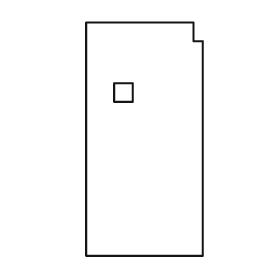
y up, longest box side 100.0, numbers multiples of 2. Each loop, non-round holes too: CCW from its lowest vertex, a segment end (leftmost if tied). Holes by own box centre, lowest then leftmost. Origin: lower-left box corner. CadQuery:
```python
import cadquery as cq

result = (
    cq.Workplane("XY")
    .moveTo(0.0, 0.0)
    .lineTo(50.0, 0.0)
    .lineTo(50.0, 92.0)
    .lineTo(46.0, 92.0)
    .lineTo(46.0, 100.0)
    .lineTo(0.0, 100.0)
    .close()
    .moveTo(12.0, 66.0)
    .lineTo(20.0, 66.0)
    .lineTo(20.0, 74.0)
    .lineTo(12.0, 74.0)
    .close()
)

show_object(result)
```